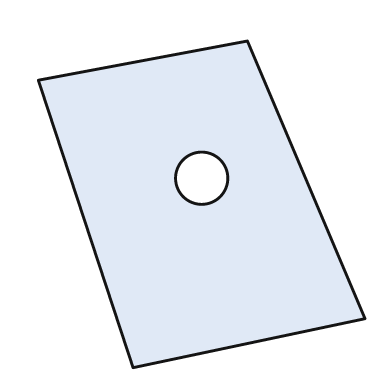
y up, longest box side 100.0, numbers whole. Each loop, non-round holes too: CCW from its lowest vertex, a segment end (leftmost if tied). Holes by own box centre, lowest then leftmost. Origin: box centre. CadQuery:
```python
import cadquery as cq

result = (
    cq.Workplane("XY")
    .moveTo(-21.0, -50.0)
    .lineTo(50.0, -35.0)
    .lineTo(14.0, 50.0)
    .lineTo(-50.0, 38.0)
    .close()
    .moveTo(0.0, 8.0)
    .circle(8.0)
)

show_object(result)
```